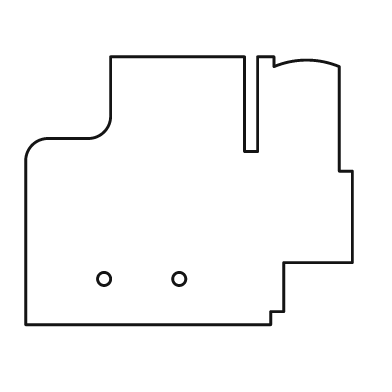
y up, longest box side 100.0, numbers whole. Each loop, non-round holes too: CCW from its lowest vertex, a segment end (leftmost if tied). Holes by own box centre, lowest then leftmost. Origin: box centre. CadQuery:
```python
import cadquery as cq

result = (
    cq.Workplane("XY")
    .moveTo(-50.0, -41.0)
    .lineTo(25.0, -41.0)
    .lineTo(25.0, -37.0)
    .lineTo(29.0, -37.0)
    .lineTo(29.0, -22.0)
    .lineTo(50.0, -22.0)
    .lineTo(50.0, 6.0)
    .lineTo(46.0, 6.0)
    .lineTo(46.0, 38.0)
    .threePointArc((36.0, 40.0), (26.0, 38.0))
    .lineTo(26.0, 41.0)
    .lineTo(21.0, 41.0)
    .lineTo(21.0, 12.0)
    .lineTo(17.0, 12.0)
    .lineTo(17.0, 41.0)
    .lineTo(-24.0, 41.0)
    .lineTo(-24.0, 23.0)
    .threePointArc((-26.0, 18.0), (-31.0, 16.0))
    .lineTo(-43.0, 16.0)
    .threePointArc((-48.0, 14.0), (-50.0, 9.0))
    .close()
    .moveTo(-26.0, -27.0)
    .circle(2.0)
    .moveTo(-3.0, -27.0)
    .circle(2.0)
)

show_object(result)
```